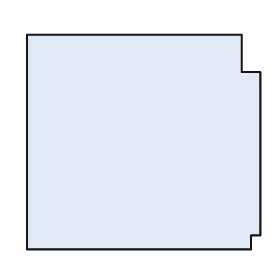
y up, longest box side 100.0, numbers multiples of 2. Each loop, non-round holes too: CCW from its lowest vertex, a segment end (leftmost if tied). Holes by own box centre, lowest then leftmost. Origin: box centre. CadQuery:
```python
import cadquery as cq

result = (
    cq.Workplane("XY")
    .moveTo(-50.0, -46.0)
    .lineTo(46.0, -46.0)
    .lineTo(46.0, -40.0)
    .lineTo(50.0, -40.0)
    .lineTo(50.0, 30.0)
    .lineTo(42.0, 30.0)
    .lineTo(42.0, 46.0)
    .lineTo(-50.0, 46.0)
    .close()
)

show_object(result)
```